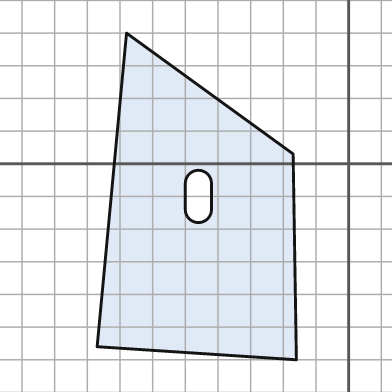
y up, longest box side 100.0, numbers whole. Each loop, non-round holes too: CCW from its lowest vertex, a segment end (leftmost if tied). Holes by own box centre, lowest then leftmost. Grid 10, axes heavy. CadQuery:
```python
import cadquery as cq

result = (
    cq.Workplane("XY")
    .moveTo(-16.0, -60.0)
    .lineTo(-17.0, 3.0)
    .lineTo(-68.0, 40.0)
    .lineTo(-77.0, -56.0)
    .close()
    .moveTo(-50.0, -14.0)
    .threePointArc((-46.0, -18.0), (-42.0, -14.0))
    .lineTo(-42.0, -6.0)
    .threePointArc((-46.0, -2.0), (-50.0, -6.0))
    .close()
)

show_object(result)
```